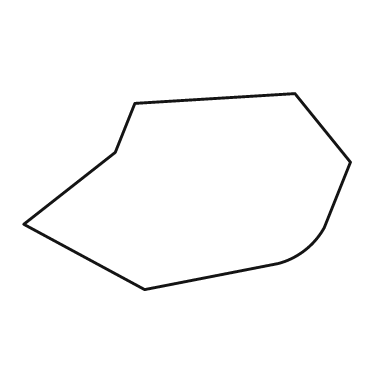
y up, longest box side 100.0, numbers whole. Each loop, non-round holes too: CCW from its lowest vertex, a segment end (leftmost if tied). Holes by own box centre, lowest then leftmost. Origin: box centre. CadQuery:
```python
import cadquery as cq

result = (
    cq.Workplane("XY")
    .moveTo(-13.0, -30.0)
    .lineTo(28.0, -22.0)
    .threePointArc((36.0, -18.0), (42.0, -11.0))
    .lineTo(50.0, 9.0)
    .lineTo(33.0, 30.0)
    .lineTo(-16.0, 27.0)
    .lineTo(-22.0, 12.0)
    .lineTo(-50.0, -10.0)
    .close()
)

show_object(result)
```